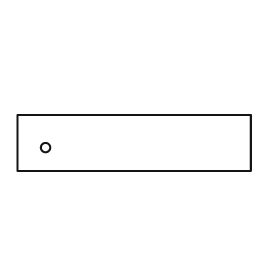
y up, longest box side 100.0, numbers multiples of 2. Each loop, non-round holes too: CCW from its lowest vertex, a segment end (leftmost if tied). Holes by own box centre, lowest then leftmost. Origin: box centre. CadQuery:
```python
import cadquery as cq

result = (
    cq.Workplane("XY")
    .moveTo(-50.0, -12.0)
    .lineTo(50.0, -12.0)
    .lineTo(50.0, 12.0)
    .lineTo(-50.0, 12.0)
    .close()
    .moveTo(-38.0, -2.0)
    .circle(2.0)
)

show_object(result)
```